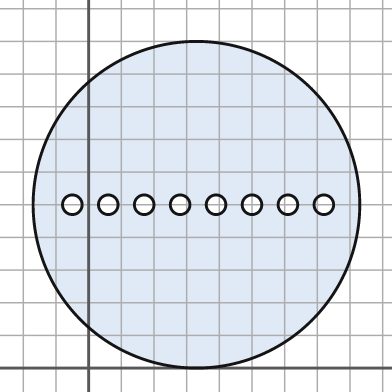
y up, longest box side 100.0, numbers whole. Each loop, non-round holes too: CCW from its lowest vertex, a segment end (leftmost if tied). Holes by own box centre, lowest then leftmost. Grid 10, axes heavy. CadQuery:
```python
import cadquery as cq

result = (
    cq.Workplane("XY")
    .moveTo(33.0, 50.0)
    .circle(50.0)
    .moveTo(-5.0, 50.0)
    .circle(3.0)
    .moveTo(6.0, 50.0)
    .circle(3.0)
    .moveTo(17.0, 50.0)
    .circle(3.0)
    .moveTo(28.0, 50.0)
    .circle(3.0)
    .moveTo(39.0, 50.0)
    .circle(3.0)
    .moveTo(50.0, 50.0)
    .circle(3.0)
    .moveTo(61.0, 50.0)
    .circle(3.0)
    .moveTo(72.0, 50.0)
    .circle(3.0)
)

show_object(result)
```